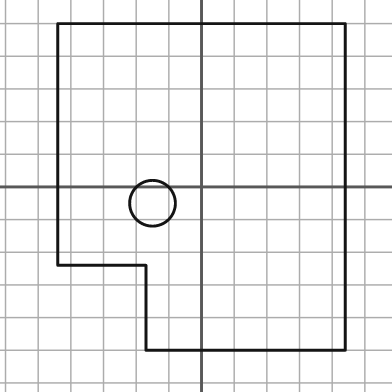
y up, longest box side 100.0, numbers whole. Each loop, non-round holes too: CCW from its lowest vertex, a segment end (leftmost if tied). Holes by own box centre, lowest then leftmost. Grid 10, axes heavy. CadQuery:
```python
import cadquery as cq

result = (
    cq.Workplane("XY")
    .moveTo(-17.0, -50.0)
    .lineTo(44.0, -50.0)
    .lineTo(44.0, 50.0)
    .lineTo(-44.0, 50.0)
    .lineTo(-44.0, -24.0)
    .lineTo(-17.0, -24.0)
    .close()
    .moveTo(-15.0, -5.0)
    .circle(7.0)
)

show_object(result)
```